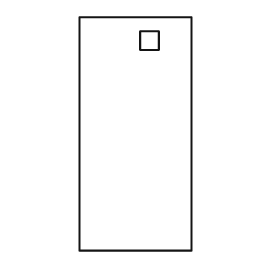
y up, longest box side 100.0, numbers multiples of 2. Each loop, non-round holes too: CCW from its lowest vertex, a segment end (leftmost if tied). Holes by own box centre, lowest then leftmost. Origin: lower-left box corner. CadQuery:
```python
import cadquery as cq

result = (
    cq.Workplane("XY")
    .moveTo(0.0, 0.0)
    .lineTo(48.0, 0.0)
    .lineTo(48.0, 100.0)
    .lineTo(0.0, 100.0)
    .close()
    .moveTo(26.0, 86.0)
    .lineTo(34.0, 86.0)
    .lineTo(34.0, 94.0)
    .lineTo(26.0, 94.0)
    .close()
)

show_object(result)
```